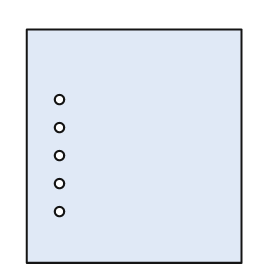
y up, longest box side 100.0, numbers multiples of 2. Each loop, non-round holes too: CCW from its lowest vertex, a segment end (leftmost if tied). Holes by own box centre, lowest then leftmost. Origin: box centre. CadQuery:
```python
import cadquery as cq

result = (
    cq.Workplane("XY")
    .moveTo(-46.0, -50.0)
    .lineTo(46.0, -50.0)
    .lineTo(46.0, 50.0)
    .lineTo(-46.0, 50.0)
    .close()
    .moveTo(-32.0, -28.0)
    .circle(2.0)
    .moveTo(-32.0, -16.0)
    .circle(2.0)
    .moveTo(-32.0, -4.0)
    .circle(2.0)
    .moveTo(-32.0, 8.0)
    .circle(2.0)
    .moveTo(-32.0, 20.0)
    .circle(2.0)
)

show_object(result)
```